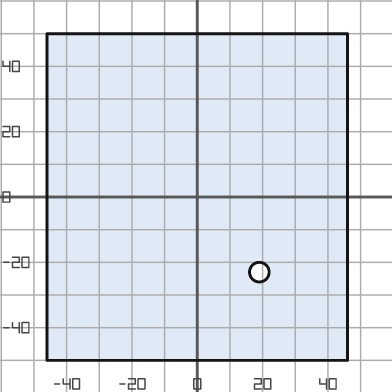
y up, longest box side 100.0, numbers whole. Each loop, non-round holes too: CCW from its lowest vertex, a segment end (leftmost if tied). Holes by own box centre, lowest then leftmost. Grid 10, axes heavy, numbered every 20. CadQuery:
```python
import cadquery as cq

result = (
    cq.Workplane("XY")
    .moveTo(-46.0, -50.0)
    .lineTo(46.0, -50.0)
    .lineTo(46.0, 50.0)
    .lineTo(-46.0, 50.0)
    .close()
    .moveTo(19.0, -23.0)
    .circle(3.0)
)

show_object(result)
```